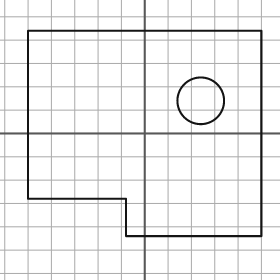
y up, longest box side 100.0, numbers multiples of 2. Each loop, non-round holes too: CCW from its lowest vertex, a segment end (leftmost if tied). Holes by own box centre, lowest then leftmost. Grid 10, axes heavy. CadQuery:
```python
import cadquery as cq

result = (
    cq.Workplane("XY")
    .moveTo(-8.0, -44.0)
    .lineTo(50.0, -44.0)
    .lineTo(50.0, 44.0)
    .lineTo(-50.0, 44.0)
    .lineTo(-50.0, -28.0)
    .lineTo(-8.0, -28.0)
    .close()
    .moveTo(24.0, 14.0)
    .circle(10.0)
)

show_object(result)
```